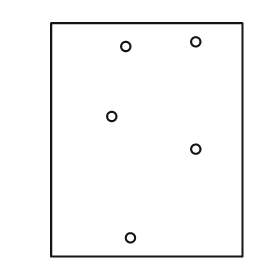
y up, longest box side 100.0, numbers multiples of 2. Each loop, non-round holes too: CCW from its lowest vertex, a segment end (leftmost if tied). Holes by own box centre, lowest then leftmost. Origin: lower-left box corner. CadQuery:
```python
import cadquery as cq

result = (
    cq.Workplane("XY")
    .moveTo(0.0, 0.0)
    .lineTo(82.0, 0.0)
    .lineTo(82.0, 100.0)
    .lineTo(0.0, 100.0)
    .close()
    .moveTo(34.0, 8.0)
    .circle(2.0)
    .moveTo(62.0, 46.0)
    .circle(2.0)
    .moveTo(26.0, 60.0)
    .circle(2.0)
    .moveTo(32.0, 90.0)
    .circle(2.0)
    .moveTo(62.0, 92.0)
    .circle(2.0)
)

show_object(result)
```